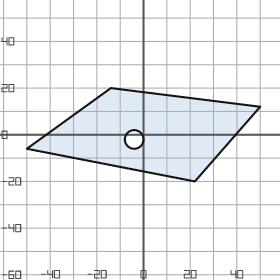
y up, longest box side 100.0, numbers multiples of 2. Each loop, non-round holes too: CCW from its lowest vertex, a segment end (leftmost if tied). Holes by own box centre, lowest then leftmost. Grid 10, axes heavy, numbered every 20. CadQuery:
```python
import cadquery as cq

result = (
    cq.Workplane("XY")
    .moveTo(22.0, -20.0)
    .lineTo(50.0, 12.0)
    .lineTo(-14.0, 20.0)
    .lineTo(-50.0, -6.0)
    .close()
    .moveTo(-4.0, -2.0)
    .circle(4.0)
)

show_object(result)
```